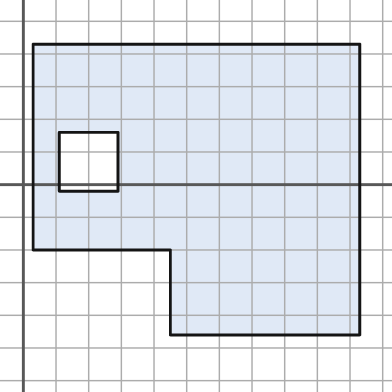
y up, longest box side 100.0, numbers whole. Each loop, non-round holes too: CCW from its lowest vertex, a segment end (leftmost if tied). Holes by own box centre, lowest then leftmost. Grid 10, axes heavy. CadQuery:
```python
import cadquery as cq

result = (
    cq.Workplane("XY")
    .moveTo(45.0, -46.0)
    .lineTo(103.0, -46.0)
    .lineTo(103.0, 43.0)
    .lineTo(3.0, 43.0)
    .lineTo(3.0, -20.0)
    .lineTo(45.0, -20.0)
    .close()
    .moveTo(11.0, -2.0)
    .lineTo(29.0, -2.0)
    .lineTo(29.0, 16.0)
    .lineTo(11.0, 16.0)
    .close()
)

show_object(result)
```